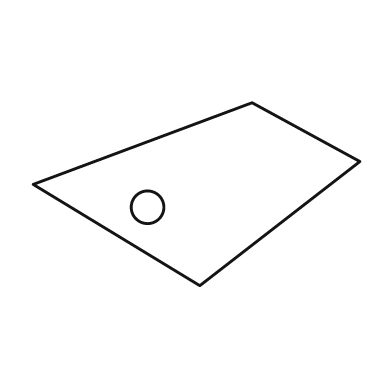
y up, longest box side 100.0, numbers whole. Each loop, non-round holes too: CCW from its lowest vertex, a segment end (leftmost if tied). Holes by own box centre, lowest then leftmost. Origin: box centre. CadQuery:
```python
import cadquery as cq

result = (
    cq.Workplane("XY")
    .moveTo(1.0, -28.0)
    .lineTo(50.0, 10.0)
    .lineTo(17.0, 28.0)
    .lineTo(-50.0, 3.0)
    .close()
    .moveTo(-15.0, -4.0)
    .circle(5.0)
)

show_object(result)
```